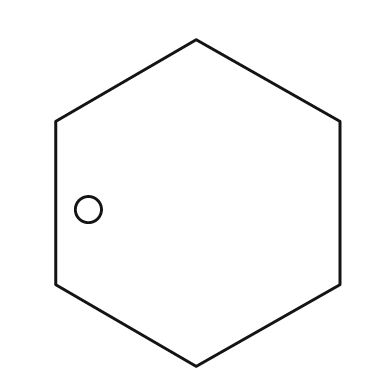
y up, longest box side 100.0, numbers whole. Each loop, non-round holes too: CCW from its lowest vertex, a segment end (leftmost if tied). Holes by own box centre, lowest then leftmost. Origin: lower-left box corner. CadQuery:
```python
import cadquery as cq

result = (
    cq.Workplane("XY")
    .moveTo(43.0, 0.0)
    .lineTo(87.0, 25.0)
    .lineTo(87.0, 75.0)
    .lineTo(43.0, 100.0)
    .lineTo(0.0, 75.0)
    .lineTo(0.0, 25.0)
    .close()
    .moveTo(10.0, 48.0)
    .circle(4.0)
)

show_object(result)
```